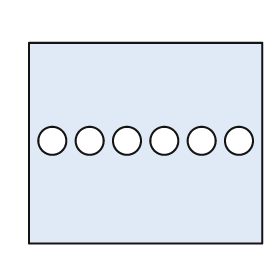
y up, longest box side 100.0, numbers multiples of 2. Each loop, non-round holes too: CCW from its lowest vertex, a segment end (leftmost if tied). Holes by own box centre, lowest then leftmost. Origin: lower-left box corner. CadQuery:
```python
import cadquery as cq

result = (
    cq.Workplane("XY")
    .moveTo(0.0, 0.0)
    .lineTo(100.0, 0.0)
    .lineTo(100.0, 86.0)
    .lineTo(0.0, 86.0)
    .close()
    .moveTo(10.0, 44.0)
    .circle(6.0)
    .moveTo(26.0, 44.0)
    .circle(6.0)
    .moveTo(42.0, 44.0)
    .circle(6.0)
    .moveTo(58.0, 44.0)
    .circle(6.0)
    .moveTo(74.0, 44.0)
    .circle(6.0)
    .moveTo(90.0, 44.0)
    .circle(6.0)
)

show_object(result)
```